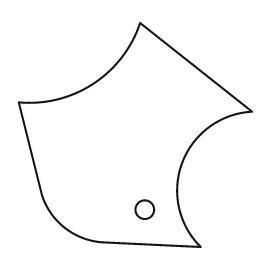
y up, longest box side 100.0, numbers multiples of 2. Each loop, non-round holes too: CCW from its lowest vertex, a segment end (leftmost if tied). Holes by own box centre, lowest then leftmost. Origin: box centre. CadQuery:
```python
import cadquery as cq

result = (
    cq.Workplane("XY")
    .moveTo(28.0, -48.0)
    .threePointArc((20.0, -12.0), (50.0, 10.0))
    .lineTo(2.0, 48.0)
    .threePointArc((-18.0, 22.0), (-50.0, 14.0))
    .lineTo(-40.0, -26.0)
    .threePointArc((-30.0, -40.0), (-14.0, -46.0))
    .close()
    .moveTo(4.0, -32.0)
    .circle(4.0)
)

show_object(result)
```